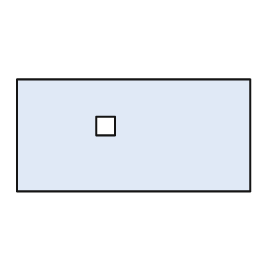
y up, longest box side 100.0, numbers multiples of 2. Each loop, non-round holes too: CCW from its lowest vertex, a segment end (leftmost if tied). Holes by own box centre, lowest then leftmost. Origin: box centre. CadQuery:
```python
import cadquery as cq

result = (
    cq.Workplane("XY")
    .moveTo(-50.0, -24.0)
    .lineTo(50.0, -24.0)
    .lineTo(50.0, 24.0)
    .lineTo(-50.0, 24.0)
    .close()
    .moveTo(-16.0, 0.0)
    .lineTo(-8.0, 0.0)
    .lineTo(-8.0, 8.0)
    .lineTo(-16.0, 8.0)
    .close()
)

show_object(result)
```